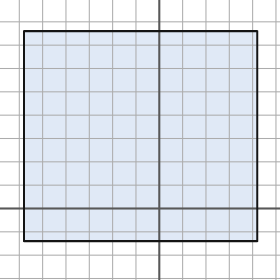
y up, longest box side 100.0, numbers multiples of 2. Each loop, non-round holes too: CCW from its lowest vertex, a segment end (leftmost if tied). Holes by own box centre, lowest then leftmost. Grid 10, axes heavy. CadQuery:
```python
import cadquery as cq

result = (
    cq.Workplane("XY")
    .moveTo(-58.0, -14.0)
    .lineTo(42.0, -14.0)
    .lineTo(42.0, 76.0)
    .lineTo(-58.0, 76.0)
    .close()
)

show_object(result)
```